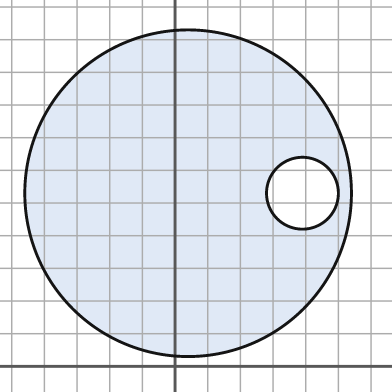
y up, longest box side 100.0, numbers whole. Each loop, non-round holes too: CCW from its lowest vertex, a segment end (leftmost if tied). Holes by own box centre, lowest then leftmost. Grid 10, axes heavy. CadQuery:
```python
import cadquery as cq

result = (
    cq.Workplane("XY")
    .moveTo(4.0, 53.0)
    .circle(50.0)
    .moveTo(39.0, 53.0)
    .circle(11.0)
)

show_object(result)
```